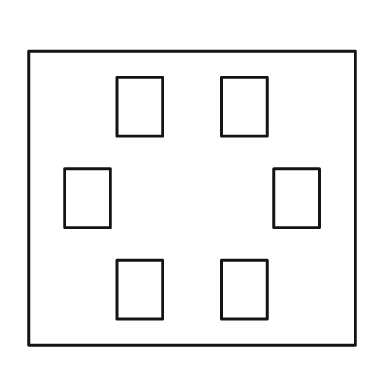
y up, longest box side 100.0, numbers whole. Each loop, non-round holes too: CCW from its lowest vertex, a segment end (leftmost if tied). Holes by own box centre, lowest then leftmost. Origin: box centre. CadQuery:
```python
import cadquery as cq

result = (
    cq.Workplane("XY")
    .moveTo(-50.0, -45.0)
    .lineTo(50.0, -45.0)
    .lineTo(50.0, 45.0)
    .lineTo(-50.0, 45.0)
    .close()
    .moveTo(-23.0, -37.0)
    .lineTo(-9.0, -37.0)
    .lineTo(-9.0, -19.0)
    .lineTo(-23.0, -19.0)
    .close()
    .moveTo(9.0, -37.0)
    .lineTo(23.0, -37.0)
    .lineTo(23.0, -19.0)
    .lineTo(9.0, -19.0)
    .close()
    .moveTo(-39.0, -9.0)
    .lineTo(-25.0, -9.0)
    .lineTo(-25.0, 9.0)
    .lineTo(-39.0, 9.0)
    .close()
    .moveTo(25.0, -9.0)
    .lineTo(39.0, -9.0)
    .lineTo(39.0, 9.0)
    .lineTo(25.0, 9.0)
    .close()
    .moveTo(-23.0, 19.0)
    .lineTo(-9.0, 19.0)
    .lineTo(-9.0, 37.0)
    .lineTo(-23.0, 37.0)
    .close()
    .moveTo(9.0, 19.0)
    .lineTo(23.0, 19.0)
    .lineTo(23.0, 37.0)
    .lineTo(9.0, 37.0)
    .close()
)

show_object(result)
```